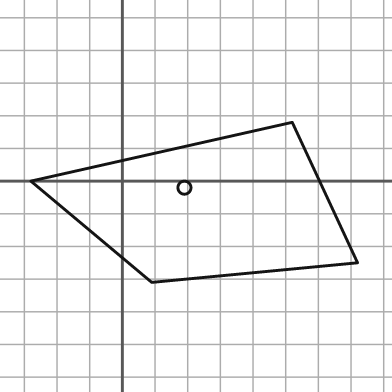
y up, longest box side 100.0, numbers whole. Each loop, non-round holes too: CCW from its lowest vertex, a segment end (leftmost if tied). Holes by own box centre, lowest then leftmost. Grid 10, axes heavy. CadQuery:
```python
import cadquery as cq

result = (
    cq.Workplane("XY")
    .moveTo(9.0, -31.0)
    .lineTo(72.0, -25.0)
    .lineTo(52.0, 18.0)
    .lineTo(-28.0, 0.0)
    .close()
    .moveTo(19.0, -2.0)
    .circle(2.0)
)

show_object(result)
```